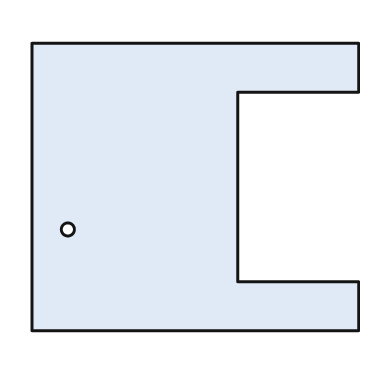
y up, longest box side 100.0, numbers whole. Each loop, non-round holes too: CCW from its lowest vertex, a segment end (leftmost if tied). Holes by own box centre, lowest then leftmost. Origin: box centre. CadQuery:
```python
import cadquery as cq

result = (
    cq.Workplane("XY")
    .moveTo(-50.0, -44.0)
    .lineTo(50.0, -44.0)
    .lineTo(50.0, -29.0)
    .lineTo(13.0, -29.0)
    .lineTo(13.0, 29.0)
    .lineTo(50.0, 29.0)
    .lineTo(50.0, 44.0)
    .lineTo(-50.0, 44.0)
    .close()
    .moveTo(-39.0, -13.0)
    .circle(2.0)
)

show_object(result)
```